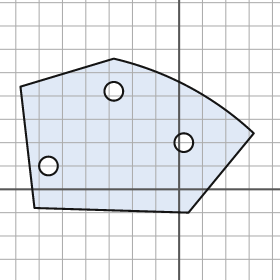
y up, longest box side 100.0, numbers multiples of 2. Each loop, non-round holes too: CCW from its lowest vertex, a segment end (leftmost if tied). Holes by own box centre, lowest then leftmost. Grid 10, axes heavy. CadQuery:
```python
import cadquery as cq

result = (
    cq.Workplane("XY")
    .moveTo(4.0, -10.0)
    .lineTo(32.0, 24.0)
    .threePointArc((4.0, 44.0), (-28.0, 56.0))
    .lineTo(-68.0, 44.0)
    .lineTo(-62.0, -8.0)
    .close()
    .moveTo(-56.0, 10.0)
    .circle(4.0)
    .moveTo(2.0, 20.0)
    .circle(4.0)
    .moveTo(-28.0, 42.0)
    .circle(4.0)
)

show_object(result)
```